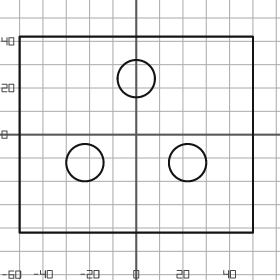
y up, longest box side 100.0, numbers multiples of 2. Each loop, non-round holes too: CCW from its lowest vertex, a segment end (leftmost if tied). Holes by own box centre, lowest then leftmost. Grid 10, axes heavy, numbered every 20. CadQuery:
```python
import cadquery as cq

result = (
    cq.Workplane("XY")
    .moveTo(-50.0, -42.0)
    .lineTo(50.0, -42.0)
    .lineTo(50.0, 42.0)
    .lineTo(-50.0, 42.0)
    .close()
    .moveTo(-22.0, -12.0)
    .circle(8.0)
    .moveTo(22.0, -12.0)
    .circle(8.0)
    .moveTo(0.0, 24.0)
    .circle(8.0)
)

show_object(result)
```